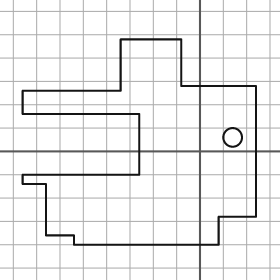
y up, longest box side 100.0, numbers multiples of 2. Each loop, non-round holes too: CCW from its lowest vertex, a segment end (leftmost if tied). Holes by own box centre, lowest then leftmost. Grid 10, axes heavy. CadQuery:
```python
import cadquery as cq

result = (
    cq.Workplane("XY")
    .moveTo(-54.0, -40.0)
    .lineTo(8.0, -40.0)
    .lineTo(8.0, -28.0)
    .lineTo(24.0, -28.0)
    .lineTo(24.0, 28.0)
    .lineTo(-8.0, 28.0)
    .lineTo(-8.0, 48.0)
    .lineTo(-34.0, 48.0)
    .lineTo(-34.0, 26.0)
    .lineTo(-76.0, 26.0)
    .lineTo(-76.0, 16.0)
    .lineTo(-26.0, 16.0)
    .lineTo(-26.0, -10.0)
    .lineTo(-76.0, -10.0)
    .lineTo(-76.0, -14.0)
    .lineTo(-66.0, -14.0)
    .lineTo(-66.0, -36.0)
    .lineTo(-54.0, -36.0)
    .close()
    .moveTo(14.0, 6.0)
    .circle(4.0)
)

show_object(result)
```